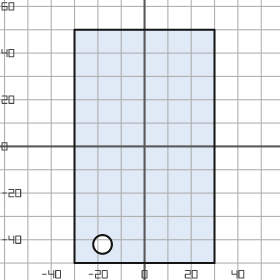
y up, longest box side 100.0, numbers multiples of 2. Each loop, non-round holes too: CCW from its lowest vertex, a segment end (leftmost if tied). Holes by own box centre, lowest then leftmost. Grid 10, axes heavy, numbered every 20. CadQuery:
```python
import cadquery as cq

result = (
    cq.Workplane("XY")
    .moveTo(-30.0, -50.0)
    .lineTo(30.0, -50.0)
    .lineTo(30.0, 50.0)
    .lineTo(-30.0, 50.0)
    .close()
    .moveTo(-18.0, -42.0)
    .circle(4.0)
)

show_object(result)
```